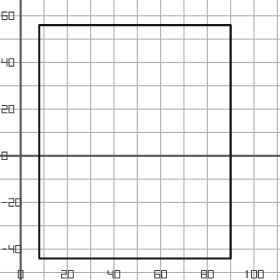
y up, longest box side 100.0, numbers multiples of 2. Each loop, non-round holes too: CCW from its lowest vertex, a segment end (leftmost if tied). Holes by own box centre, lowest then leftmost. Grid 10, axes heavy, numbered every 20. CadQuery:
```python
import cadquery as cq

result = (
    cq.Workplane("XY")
    .moveTo(8.0, -44.0)
    .lineTo(90.0, -44.0)
    .lineTo(90.0, 56.0)
    .lineTo(8.0, 56.0)
    .close()
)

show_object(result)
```